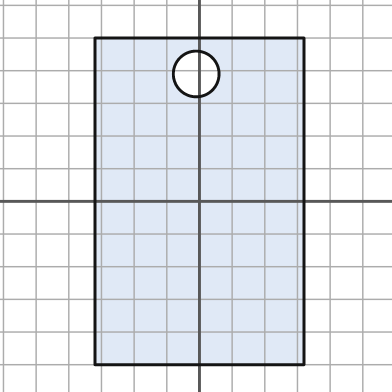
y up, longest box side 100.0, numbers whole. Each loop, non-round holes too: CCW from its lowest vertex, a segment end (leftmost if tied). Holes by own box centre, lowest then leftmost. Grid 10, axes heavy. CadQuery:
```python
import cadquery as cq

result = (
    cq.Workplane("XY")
    .moveTo(-32.0, -50.0)
    .lineTo(32.0, -50.0)
    .lineTo(32.0, 50.0)
    .lineTo(-32.0, 50.0)
    .close()
    .moveTo(-1.0, 39.0)
    .circle(7.0)
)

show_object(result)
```